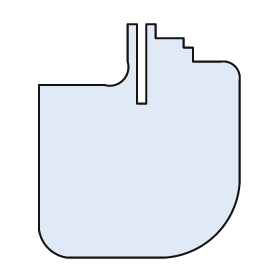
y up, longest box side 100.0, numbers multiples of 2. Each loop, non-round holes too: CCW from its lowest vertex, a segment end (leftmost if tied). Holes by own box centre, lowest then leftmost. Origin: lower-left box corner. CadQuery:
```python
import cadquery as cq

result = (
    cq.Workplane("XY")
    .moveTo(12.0, 0.0)
    .lineTo(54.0, 0.0)
    .threePointArc((76.0, 10.0), (86.0, 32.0))
    .lineTo(86.0, 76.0)
    .threePointArc((84.0, 82.0), (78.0, 84.0))
    .lineTo(66.0, 84.0)
    .lineTo(66.0, 90.0)
    .lineTo(62.0, 90.0)
    .lineTo(62.0, 94.0)
    .lineTo(50.0, 94.0)
    .lineTo(50.0, 100.0)
    .lineTo(46.0, 100.0)
    .lineTo(46.0, 66.0)
    .lineTo(42.0, 66.0)
    .lineTo(42.0, 100.0)
    .lineTo(38.0, 100.0)
    .lineTo(38.0, 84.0)
    .threePointArc((36.0, 76.0), (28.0, 74.0))
    .lineTo(0.0, 74.0)
    .lineTo(0.0, 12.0)
    .threePointArc((4.0, 4.0), (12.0, 0.0))
    .close()
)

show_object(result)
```